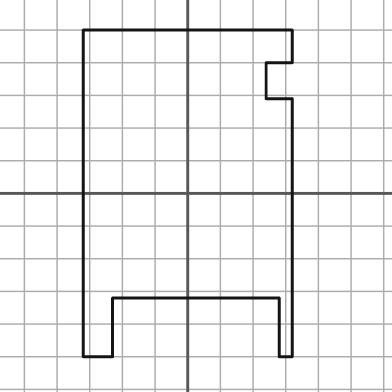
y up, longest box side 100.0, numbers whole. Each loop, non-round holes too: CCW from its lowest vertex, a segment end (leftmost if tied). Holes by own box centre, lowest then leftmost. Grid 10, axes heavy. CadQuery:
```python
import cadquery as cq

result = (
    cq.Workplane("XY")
    .moveTo(-32.0, -50.0)
    .lineTo(-23.0, -50.0)
    .lineTo(-23.0, -32.0)
    .lineTo(28.0, -32.0)
    .lineTo(28.0, -50.0)
    .lineTo(32.0, -50.0)
    .lineTo(32.0, 29.0)
    .lineTo(24.0, 29.0)
    .lineTo(24.0, 40.0)
    .lineTo(32.0, 40.0)
    .lineTo(32.0, 50.0)
    .lineTo(-32.0, 50.0)
    .close()
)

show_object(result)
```